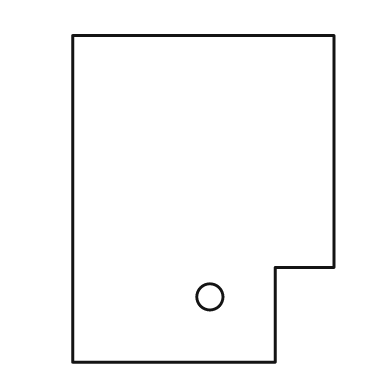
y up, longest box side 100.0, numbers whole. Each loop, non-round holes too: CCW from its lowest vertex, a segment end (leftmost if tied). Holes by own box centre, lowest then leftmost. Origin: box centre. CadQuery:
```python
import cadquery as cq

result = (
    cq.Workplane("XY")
    .moveTo(-40.0, -50.0)
    .lineTo(22.0, -50.0)
    .lineTo(22.0, -21.0)
    .lineTo(40.0, -21.0)
    .lineTo(40.0, 50.0)
    .lineTo(-40.0, 50.0)
    .close()
    .moveTo(2.0, -30.0)
    .circle(4.0)
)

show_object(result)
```